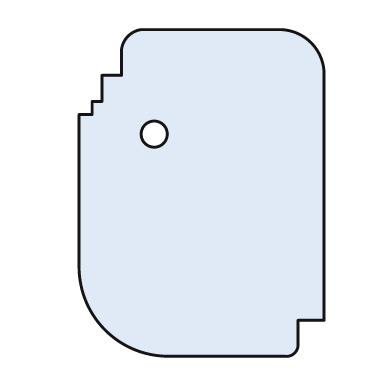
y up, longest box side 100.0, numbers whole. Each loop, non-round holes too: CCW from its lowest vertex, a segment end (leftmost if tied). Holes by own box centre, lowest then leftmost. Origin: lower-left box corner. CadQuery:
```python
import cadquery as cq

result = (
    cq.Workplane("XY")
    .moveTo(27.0, 0.0)
    .lineTo(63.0, 0.0)
    .threePointArc((66.0, 1.0), (67.0, 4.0))
    .lineTo(67.0, 11.0)
    .lineTo(75.0, 11.0)
    .lineTo(75.0, 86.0)
    .threePointArc((71.0, 96.0), (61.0, 100.0))
    .lineTo(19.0, 100.0)
    .threePointArc((15.0, 98.0), (13.0, 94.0))
    .lineTo(13.0, 86.0)
    .lineTo(7.0, 86.0)
    .lineTo(7.0, 78.0)
    .lineTo(4.0, 78.0)
    .lineTo(4.0, 74.0)
    .lineTo(0.0, 74.0)
    .lineTo(0.0, 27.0)
    .threePointArc((8.0, 8.0), (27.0, 0.0))
    .close()
    .moveTo(23.0, 68.0)
    .circle(4.0)
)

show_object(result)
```